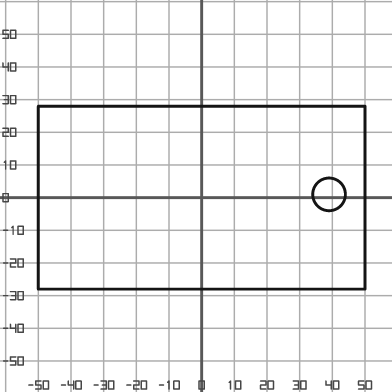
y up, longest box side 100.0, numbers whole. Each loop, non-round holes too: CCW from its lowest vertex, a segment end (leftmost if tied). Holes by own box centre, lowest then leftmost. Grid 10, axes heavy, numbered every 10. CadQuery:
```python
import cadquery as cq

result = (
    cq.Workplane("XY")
    .moveTo(-50.0, -28.0)
    .lineTo(50.0, -28.0)
    .lineTo(50.0, 28.0)
    .lineTo(-50.0, 28.0)
    .close()
    .moveTo(39.0, 1.0)
    .circle(5.0)
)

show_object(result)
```